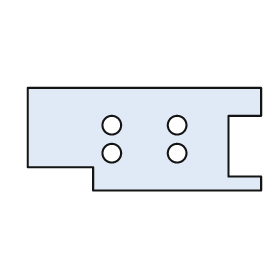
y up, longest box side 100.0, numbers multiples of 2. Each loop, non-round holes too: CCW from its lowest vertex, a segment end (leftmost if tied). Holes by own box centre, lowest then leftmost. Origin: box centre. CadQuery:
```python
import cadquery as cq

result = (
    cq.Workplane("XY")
    .moveTo(-22.0, -22.0)
    .lineTo(50.0, -22.0)
    .lineTo(50.0, -16.0)
    .lineTo(36.0, -16.0)
    .lineTo(36.0, 10.0)
    .lineTo(50.0, 10.0)
    .lineTo(50.0, 22.0)
    .lineTo(-50.0, 22.0)
    .lineTo(-50.0, -12.0)
    .lineTo(-22.0, -12.0)
    .close()
    .moveTo(-14.0, -6.0)
    .circle(4.0)
    .moveTo(14.0, -6.0)
    .circle(4.0)
    .moveTo(-14.0, 6.0)
    .circle(4.0)
    .moveTo(14.0, 6.0)
    .circle(4.0)
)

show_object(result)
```